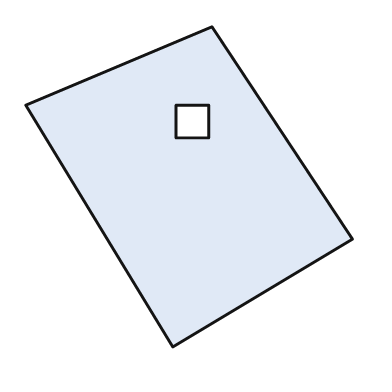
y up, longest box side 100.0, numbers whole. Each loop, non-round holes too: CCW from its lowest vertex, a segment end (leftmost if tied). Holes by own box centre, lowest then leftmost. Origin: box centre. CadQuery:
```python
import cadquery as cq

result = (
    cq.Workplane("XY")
    .moveTo(-5.0, -49.0)
    .lineTo(50.0, -16.0)
    .lineTo(7.0, 49.0)
    .lineTo(-50.0, 25.0)
    .close()
    .moveTo(-4.0, 15.0)
    .lineTo(6.0, 15.0)
    .lineTo(6.0, 25.0)
    .lineTo(-4.0, 25.0)
    .close()
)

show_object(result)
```